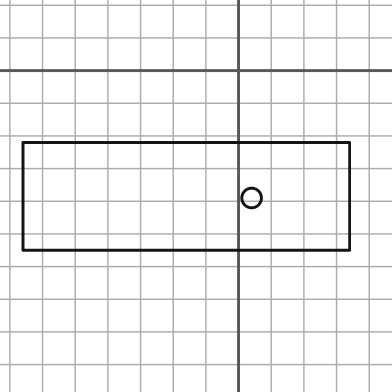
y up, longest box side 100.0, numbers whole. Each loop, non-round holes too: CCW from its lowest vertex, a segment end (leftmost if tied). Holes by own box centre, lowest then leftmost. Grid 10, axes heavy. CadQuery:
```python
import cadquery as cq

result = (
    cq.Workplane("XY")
    .moveTo(-66.0, -55.0)
    .lineTo(34.0, -55.0)
    .lineTo(34.0, -22.0)
    .lineTo(-66.0, -22.0)
    .close()
    .moveTo(4.0, -39.0)
    .circle(3.0)
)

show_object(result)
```